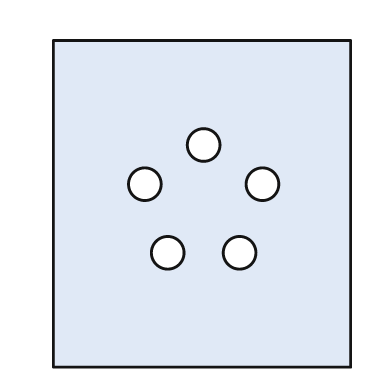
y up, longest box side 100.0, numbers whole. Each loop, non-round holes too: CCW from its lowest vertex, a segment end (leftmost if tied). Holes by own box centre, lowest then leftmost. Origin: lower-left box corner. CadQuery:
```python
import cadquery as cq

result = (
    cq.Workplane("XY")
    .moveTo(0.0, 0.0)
    .lineTo(91.0, 0.0)
    .lineTo(91.0, 100.0)
    .lineTo(0.0, 100.0)
    .close()
    .moveTo(35.0, 35.0)
    .circle(5.0)
    .moveTo(57.0, 35.0)
    .circle(5.0)
    .moveTo(28.0, 56.0)
    .circle(5.0)
    .moveTo(64.0, 56.0)
    .circle(5.0)
    .moveTo(46.0, 68.0)
    .circle(5.0)
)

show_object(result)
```